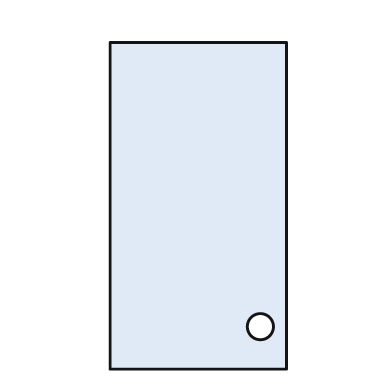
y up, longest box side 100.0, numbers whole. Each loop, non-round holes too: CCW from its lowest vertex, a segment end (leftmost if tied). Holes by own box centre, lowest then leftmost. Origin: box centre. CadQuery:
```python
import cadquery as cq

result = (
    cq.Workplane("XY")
    .moveTo(-27.0, -50.0)
    .lineTo(27.0, -50.0)
    .lineTo(27.0, 50.0)
    .lineTo(-27.0, 50.0)
    .close()
    .moveTo(19.0, -37.0)
    .circle(4.0)
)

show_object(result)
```